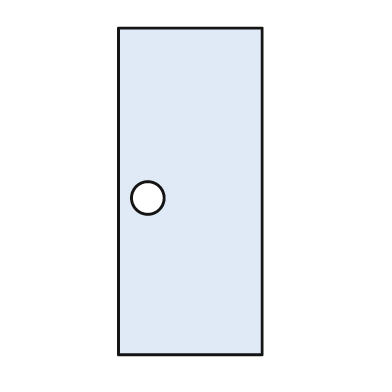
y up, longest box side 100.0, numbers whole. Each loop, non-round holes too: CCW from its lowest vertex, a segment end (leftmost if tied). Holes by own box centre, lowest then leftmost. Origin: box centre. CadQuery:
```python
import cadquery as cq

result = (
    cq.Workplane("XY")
    .moveTo(-22.0, -50.0)
    .lineTo(22.0, -50.0)
    .lineTo(22.0, 50.0)
    .lineTo(-22.0, 50.0)
    .close()
    .moveTo(-13.0, -2.0)
    .circle(5.0)
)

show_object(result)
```